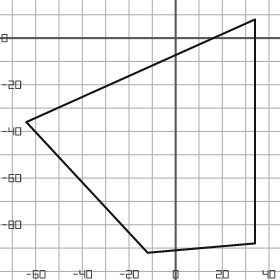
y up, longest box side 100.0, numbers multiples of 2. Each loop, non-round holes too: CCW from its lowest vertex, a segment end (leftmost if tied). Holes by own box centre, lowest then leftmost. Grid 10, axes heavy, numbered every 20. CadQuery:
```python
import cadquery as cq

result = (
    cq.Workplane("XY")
    .moveTo(-12.0, -92.0)
    .lineTo(34.0, -88.0)
    .lineTo(34.0, 8.0)
    .lineTo(-64.0, -36.0)
    .close()
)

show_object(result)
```